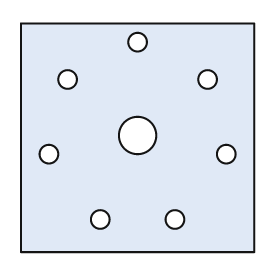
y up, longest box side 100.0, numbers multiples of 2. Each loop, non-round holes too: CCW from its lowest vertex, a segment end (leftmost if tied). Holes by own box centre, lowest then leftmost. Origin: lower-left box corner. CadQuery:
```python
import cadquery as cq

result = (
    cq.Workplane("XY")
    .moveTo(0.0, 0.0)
    .lineTo(100.0, 0.0)
    .lineTo(100.0, 98.0)
    .lineTo(0.0, 98.0)
    .close()
    .moveTo(34.0, 14.0)
    .circle(4.0)
    .moveTo(66.0, 14.0)
    .circle(4.0)
    .moveTo(12.0, 42.0)
    .circle(4.0)
    .moveTo(88.0, 42.0)
    .circle(4.0)
    .moveTo(50.0, 50.0)
    .circle(8.0)
    .moveTo(20.0, 74.0)
    .circle(4.0)
    .moveTo(80.0, 74.0)
    .circle(4.0)
    .moveTo(50.0, 90.0)
    .circle(4.0)
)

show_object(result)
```